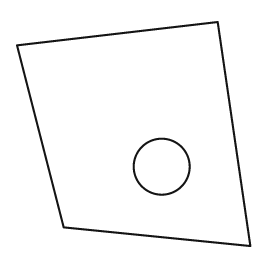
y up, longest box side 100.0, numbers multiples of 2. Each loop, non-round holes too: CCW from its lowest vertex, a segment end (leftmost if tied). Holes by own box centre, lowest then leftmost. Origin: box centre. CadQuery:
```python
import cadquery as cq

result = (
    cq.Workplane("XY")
    .moveTo(50.0, -48.0)
    .lineTo(36.0, 48.0)
    .lineTo(-50.0, 38.0)
    .lineTo(-30.0, -40.0)
    .close()
    .moveTo(12.0, -14.0)
    .circle(12.0)
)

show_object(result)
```